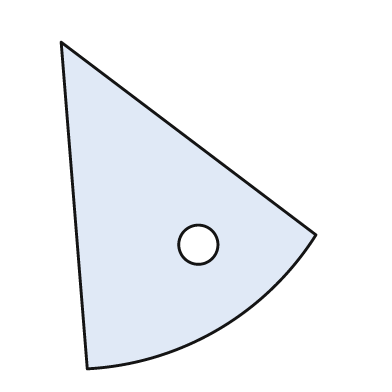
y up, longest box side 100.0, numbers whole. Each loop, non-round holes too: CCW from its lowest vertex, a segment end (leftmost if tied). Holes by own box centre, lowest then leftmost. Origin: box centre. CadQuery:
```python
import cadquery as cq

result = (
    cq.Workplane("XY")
    .moveTo(-31.0, -50.0)
    .threePointArc((9.0, -38.0), (39.0, -9.0))
    .lineTo(-39.0, 50.0)
    .close()
    .moveTo(3.0, -12.0)
    .circle(6.0)
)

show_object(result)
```